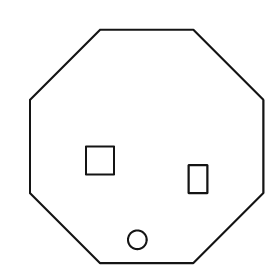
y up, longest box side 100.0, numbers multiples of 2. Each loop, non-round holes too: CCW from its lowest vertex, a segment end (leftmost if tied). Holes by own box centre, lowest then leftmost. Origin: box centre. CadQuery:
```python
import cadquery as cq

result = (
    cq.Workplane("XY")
    .moveTo(-20.0, -50.0)
    .lineTo(20.0, -50.0)
    .lineTo(50.0, -20.0)
    .lineTo(50.0, 20.0)
    .lineTo(20.0, 50.0)
    .lineTo(-20.0, 50.0)
    .lineTo(-50.0, 20.0)
    .lineTo(-50.0, -20.0)
    .close()
    .moveTo(-4.0, -40.0)
    .circle(4.0)
    .moveTo(18.0, -20.0)
    .lineTo(26.0, -20.0)
    .lineTo(26.0, -8.0)
    .lineTo(18.0, -8.0)
    .close()
    .moveTo(-26.0, -12.0)
    .lineTo(-14.0, -12.0)
    .lineTo(-14.0, 0.0)
    .lineTo(-26.0, 0.0)
    .close()
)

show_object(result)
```